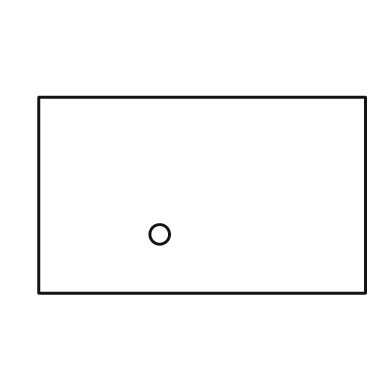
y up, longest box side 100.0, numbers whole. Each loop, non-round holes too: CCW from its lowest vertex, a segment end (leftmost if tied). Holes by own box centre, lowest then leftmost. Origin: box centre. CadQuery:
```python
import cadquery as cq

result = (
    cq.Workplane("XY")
    .moveTo(-50.0, -30.0)
    .lineTo(50.0, -30.0)
    .lineTo(50.0, 30.0)
    .lineTo(-50.0, 30.0)
    .close()
    .moveTo(-13.0, -12.0)
    .circle(3.0)
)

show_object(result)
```